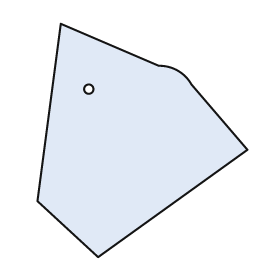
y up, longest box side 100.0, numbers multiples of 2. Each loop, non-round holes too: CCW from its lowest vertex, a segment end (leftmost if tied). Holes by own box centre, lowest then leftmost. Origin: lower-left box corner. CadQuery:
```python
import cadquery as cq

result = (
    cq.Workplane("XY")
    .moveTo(26.0, 0.0)
    .lineTo(90.0, 46.0)
    .lineTo(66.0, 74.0)
    .threePointArc((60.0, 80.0), (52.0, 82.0))
    .lineTo(10.0, 100.0)
    .lineTo(0.0, 24.0)
    .close()
    .moveTo(22.0, 72.0)
    .circle(2.0)
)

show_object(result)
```